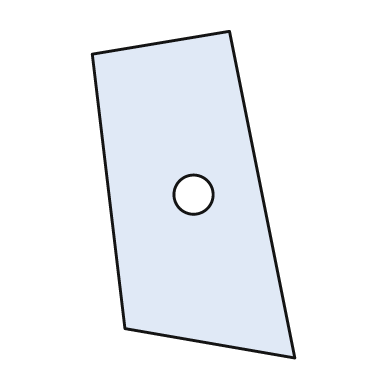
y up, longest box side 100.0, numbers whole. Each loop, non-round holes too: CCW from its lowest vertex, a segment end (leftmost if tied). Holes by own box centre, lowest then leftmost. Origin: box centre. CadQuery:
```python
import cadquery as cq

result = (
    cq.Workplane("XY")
    .moveTo(31.0, -50.0)
    .lineTo(11.0, 50.0)
    .lineTo(-31.0, 43.0)
    .lineTo(-21.0, -41.0)
    .close()
    .moveTo(0.0, 0.0)
    .circle(6.0)
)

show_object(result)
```